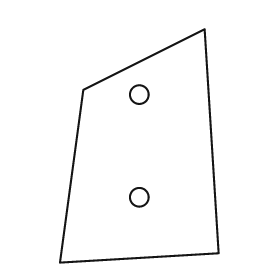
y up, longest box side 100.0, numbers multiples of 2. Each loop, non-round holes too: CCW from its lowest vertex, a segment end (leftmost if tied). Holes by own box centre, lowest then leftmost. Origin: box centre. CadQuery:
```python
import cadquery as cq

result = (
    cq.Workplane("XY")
    .moveTo(-34.0, -50.0)
    .lineTo(34.0, -46.0)
    .lineTo(28.0, 50.0)
    .lineTo(-24.0, 24.0)
    .close()
    .moveTo(0.0, -22.0)
    .circle(4.0)
    .moveTo(0.0, 22.0)
    .circle(4.0)
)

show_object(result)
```